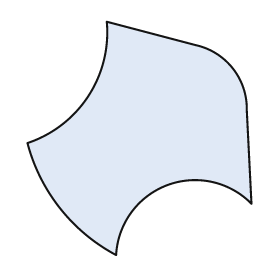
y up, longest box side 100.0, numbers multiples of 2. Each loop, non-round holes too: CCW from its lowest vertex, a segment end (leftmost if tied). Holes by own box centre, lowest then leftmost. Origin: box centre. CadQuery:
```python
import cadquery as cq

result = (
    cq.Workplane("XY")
    .moveTo(-10.0, -50.0)
    .threePointArc((12.0, -20.0), (48.0, -28.0))
    .lineTo(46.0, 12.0)
    .threePointArc((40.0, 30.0), (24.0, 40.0))
    .lineTo(-14.0, 50.0)
    .threePointArc((-22.0, 18.0), (-48.0, -2.0))
    .threePointArc((-34.0, -30.0), (-10.0, -50.0))
    .close()
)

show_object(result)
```